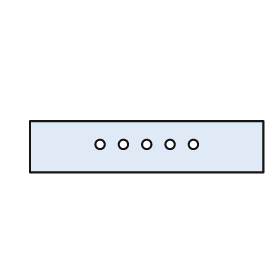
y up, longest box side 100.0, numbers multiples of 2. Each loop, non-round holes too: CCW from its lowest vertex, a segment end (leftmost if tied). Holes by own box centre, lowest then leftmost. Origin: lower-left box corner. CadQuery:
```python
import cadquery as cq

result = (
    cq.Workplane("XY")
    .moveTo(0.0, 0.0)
    .lineTo(100.0, 0.0)
    .lineTo(100.0, 22.0)
    .lineTo(0.0, 22.0)
    .close()
    .moveTo(30.0, 12.0)
    .circle(2.0)
    .moveTo(40.0, 12.0)
    .circle(2.0)
    .moveTo(50.0, 12.0)
    .circle(2.0)
    .moveTo(60.0, 12.0)
    .circle(2.0)
    .moveTo(70.0, 12.0)
    .circle(2.0)
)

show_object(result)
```